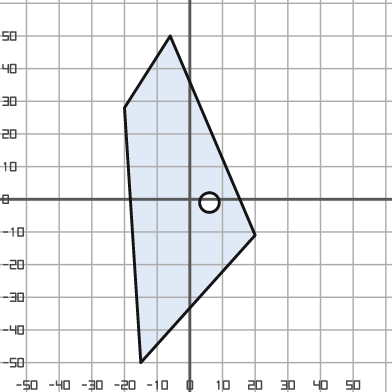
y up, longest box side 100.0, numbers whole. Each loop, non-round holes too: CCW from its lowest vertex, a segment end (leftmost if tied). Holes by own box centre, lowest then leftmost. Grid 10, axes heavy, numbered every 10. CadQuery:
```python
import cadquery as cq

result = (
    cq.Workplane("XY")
    .moveTo(-15.0, -50.0)
    .lineTo(20.0, -11.0)
    .lineTo(-6.0, 50.0)
    .lineTo(-20.0, 28.0)
    .close()
    .moveTo(6.0, -1.0)
    .circle(3.0)
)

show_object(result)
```